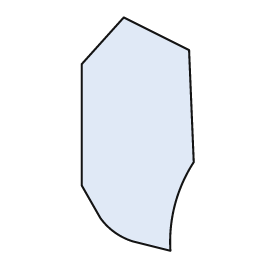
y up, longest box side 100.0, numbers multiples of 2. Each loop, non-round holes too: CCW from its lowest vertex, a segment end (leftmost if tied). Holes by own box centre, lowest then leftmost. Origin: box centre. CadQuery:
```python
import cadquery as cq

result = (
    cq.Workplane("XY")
    .moveTo(14.0, -50.0)
    .threePointArc((16.0, -30.0), (24.0, -12.0))
    .lineTo(22.0, 36.0)
    .lineTo(-6.0, 50.0)
    .lineTo(-24.0, 30.0)
    .lineTo(-24.0, -22.0)
    .lineTo(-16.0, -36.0)
    .threePointArc((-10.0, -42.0), (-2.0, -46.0))
    .close()
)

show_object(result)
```